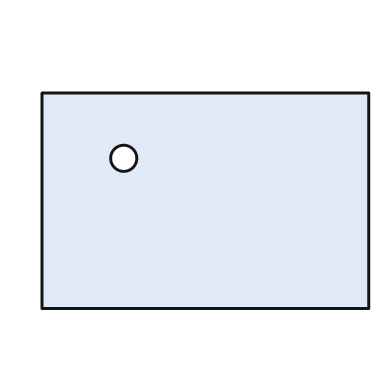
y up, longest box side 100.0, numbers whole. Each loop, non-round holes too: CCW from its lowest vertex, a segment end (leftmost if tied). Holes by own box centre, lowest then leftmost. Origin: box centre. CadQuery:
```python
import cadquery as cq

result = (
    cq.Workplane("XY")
    .moveTo(-50.0, -33.0)
    .lineTo(50.0, -33.0)
    .lineTo(50.0, 33.0)
    .lineTo(-50.0, 33.0)
    .close()
    .moveTo(-25.0, 13.0)
    .circle(4.0)
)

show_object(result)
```